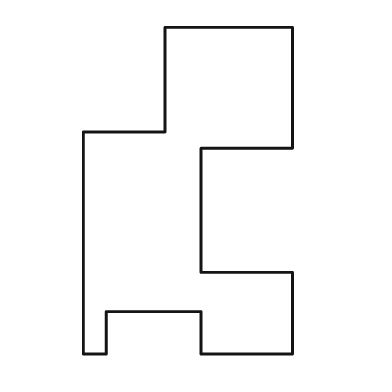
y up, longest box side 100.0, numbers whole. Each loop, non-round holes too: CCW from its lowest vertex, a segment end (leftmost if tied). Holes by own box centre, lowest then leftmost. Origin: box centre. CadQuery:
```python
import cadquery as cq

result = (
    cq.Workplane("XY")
    .moveTo(-32.0, -50.0)
    .lineTo(-25.0, -50.0)
    .lineTo(-25.0, -37.0)
    .lineTo(4.0, -37.0)
    .lineTo(4.0, -50.0)
    .lineTo(32.0, -50.0)
    .lineTo(32.0, -25.0)
    .lineTo(4.0, -25.0)
    .lineTo(4.0, 13.0)
    .lineTo(32.0, 13.0)
    .lineTo(32.0, 50.0)
    .lineTo(-7.0, 50.0)
    .lineTo(-7.0, 18.0)
    .lineTo(-32.0, 18.0)
    .close()
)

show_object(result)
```